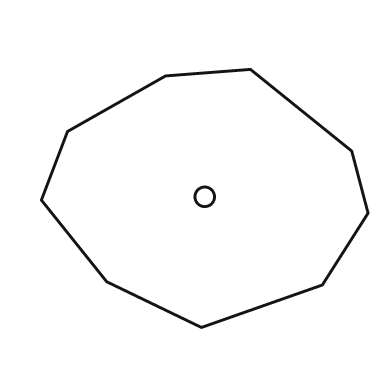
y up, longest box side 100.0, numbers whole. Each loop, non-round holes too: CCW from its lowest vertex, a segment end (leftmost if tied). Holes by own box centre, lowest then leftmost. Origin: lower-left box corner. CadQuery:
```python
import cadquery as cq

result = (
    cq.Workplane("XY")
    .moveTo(49.0, 0.0)
    .lineTo(86.0, 13.0)
    .lineTo(100.0, 35.0)
    .lineTo(95.0, 54.0)
    .lineTo(64.0, 79.0)
    .lineTo(38.0, 77.0)
    .lineTo(8.0, 60.0)
    .lineTo(0.0, 39.0)
    .lineTo(20.0, 14.0)
    .close()
    .moveTo(50.0, 40.0)
    .circle(3.0)
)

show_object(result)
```